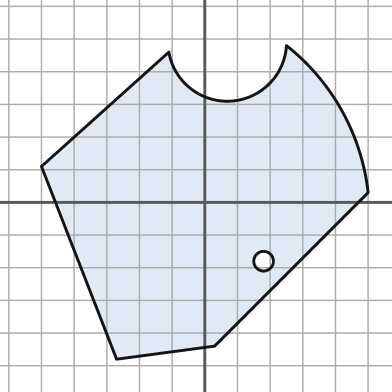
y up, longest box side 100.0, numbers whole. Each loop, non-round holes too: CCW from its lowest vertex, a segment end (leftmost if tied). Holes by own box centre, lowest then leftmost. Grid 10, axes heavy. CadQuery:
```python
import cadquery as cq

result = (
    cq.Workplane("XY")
    .moveTo(-27.0, -48.0)
    .lineTo(3.0, -44.0)
    .lineTo(50.0, 3.0)
    .threePointArc((42.0, 28.0), (25.0, 48.0))
    .threePointArc((8.0, 31.0), (-11.0, 46.0))
    .lineTo(-50.0, 11.0)
    .close()
    .moveTo(18.0, -18.0)
    .circle(3.0)
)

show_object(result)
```